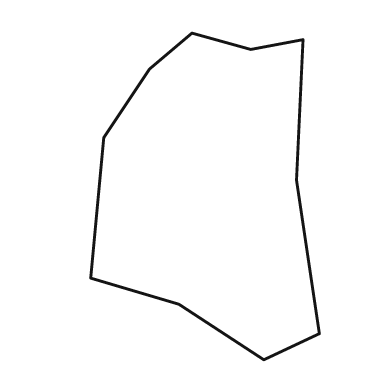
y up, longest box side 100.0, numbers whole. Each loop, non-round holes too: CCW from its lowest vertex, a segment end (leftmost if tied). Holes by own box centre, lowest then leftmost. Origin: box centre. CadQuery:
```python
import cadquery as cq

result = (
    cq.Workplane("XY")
    .moveTo(18.0, -50.0)
    .lineTo(35.0, -42.0)
    .lineTo(28.0, 5.0)
    .lineTo(30.0, 48.0)
    .lineTo(14.0, 45.0)
    .lineTo(-4.0, 50.0)
    .lineTo(-17.0, 39.0)
    .lineTo(-31.0, 18.0)
    .lineTo(-35.0, -25.0)
    .lineTo(-8.0, -33.0)
    .close()
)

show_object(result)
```